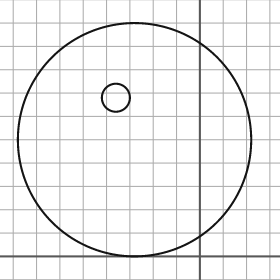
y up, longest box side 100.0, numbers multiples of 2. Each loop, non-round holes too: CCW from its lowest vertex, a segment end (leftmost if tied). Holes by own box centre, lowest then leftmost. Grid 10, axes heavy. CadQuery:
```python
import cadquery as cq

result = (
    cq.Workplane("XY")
    .moveTo(-28.0, 50.0)
    .circle(50.0)
    .moveTo(-36.0, 68.0)
    .circle(6.0)
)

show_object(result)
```